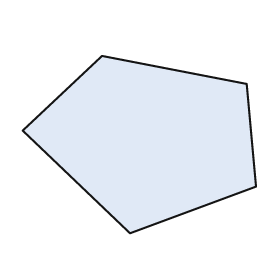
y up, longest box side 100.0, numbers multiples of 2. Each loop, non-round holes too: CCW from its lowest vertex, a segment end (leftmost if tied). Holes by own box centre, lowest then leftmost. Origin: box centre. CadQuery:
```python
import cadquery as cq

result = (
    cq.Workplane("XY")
    .moveTo(-4.0, -38.0)
    .lineTo(50.0, -18.0)
    .lineTo(46.0, 26.0)
    .lineTo(-16.0, 38.0)
    .lineTo(-50.0, 6.0)
    .close()
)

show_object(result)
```